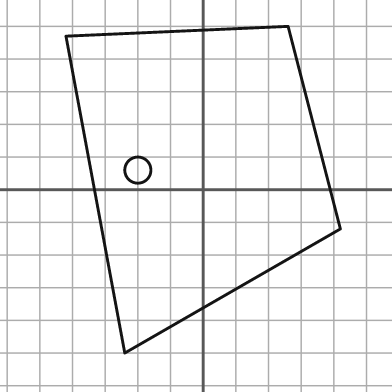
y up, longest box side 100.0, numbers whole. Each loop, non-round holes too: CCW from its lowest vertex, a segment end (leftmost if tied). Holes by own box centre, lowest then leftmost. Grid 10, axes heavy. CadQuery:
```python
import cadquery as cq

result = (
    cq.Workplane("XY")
    .moveTo(-24.0, -50.0)
    .lineTo(42.0, -12.0)
    .lineTo(26.0, 50.0)
    .lineTo(-42.0, 47.0)
    .close()
    .moveTo(-20.0, 6.0)
    .circle(4.0)
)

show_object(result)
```